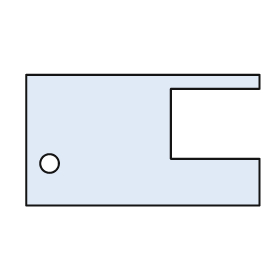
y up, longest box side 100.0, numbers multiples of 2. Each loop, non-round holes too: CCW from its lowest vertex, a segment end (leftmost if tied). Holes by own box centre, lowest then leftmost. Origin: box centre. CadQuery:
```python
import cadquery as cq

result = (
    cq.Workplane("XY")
    .moveTo(-50.0, -28.0)
    .lineTo(50.0, -28.0)
    .lineTo(50.0, -8.0)
    .lineTo(12.0, -8.0)
    .lineTo(12.0, 22.0)
    .lineTo(50.0, 22.0)
    .lineTo(50.0, 28.0)
    .lineTo(-50.0, 28.0)
    .close()
    .moveTo(-40.0, -10.0)
    .circle(4.0)
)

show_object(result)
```